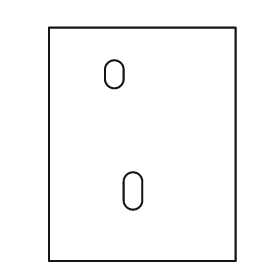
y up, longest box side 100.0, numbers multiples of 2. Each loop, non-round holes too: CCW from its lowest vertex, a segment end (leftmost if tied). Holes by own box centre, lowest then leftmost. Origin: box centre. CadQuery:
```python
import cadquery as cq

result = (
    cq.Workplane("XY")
    .moveTo(-40.0, -50.0)
    .lineTo(40.0, -50.0)
    .lineTo(40.0, 50.0)
    .lineTo(-40.0, 50.0)
    .close()
    .moveTo(-8.0, -24.0)
    .threePointArc((-4.0, -28.0), (0.0, -24.0))
    .lineTo(0.0, -16.0)
    .threePointArc((-4.0, -12.0), (-8.0, -16.0))
    .close()
    .moveTo(-16.0, 28.0)
    .threePointArc((-12.0, 24.0), (-8.0, 28.0))
    .lineTo(-8.0, 32.0)
    .threePointArc((-12.0, 36.0), (-16.0, 32.0))
    .close()
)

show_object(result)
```